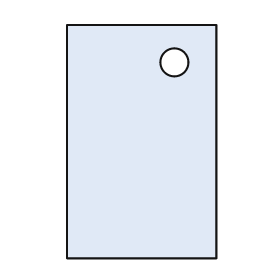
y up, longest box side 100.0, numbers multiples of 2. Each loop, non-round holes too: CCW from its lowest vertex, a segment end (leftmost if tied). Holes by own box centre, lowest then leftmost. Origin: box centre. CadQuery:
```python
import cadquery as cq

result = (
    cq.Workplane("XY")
    .moveTo(-32.0, -50.0)
    .lineTo(32.0, -50.0)
    .lineTo(32.0, 50.0)
    .lineTo(-32.0, 50.0)
    .close()
    .moveTo(14.0, 34.0)
    .circle(6.0)
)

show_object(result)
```